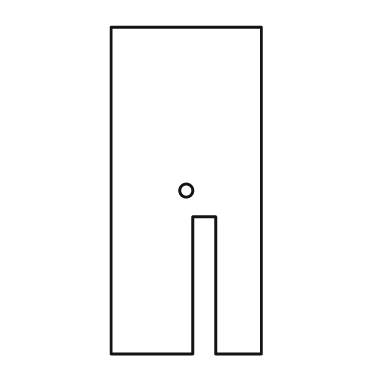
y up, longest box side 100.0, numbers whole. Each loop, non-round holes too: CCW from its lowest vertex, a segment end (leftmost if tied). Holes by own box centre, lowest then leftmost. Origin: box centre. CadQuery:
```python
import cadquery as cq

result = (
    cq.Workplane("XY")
    .moveTo(-23.0, -50.0)
    .lineTo(2.0, -50.0)
    .lineTo(2.0, -8.0)
    .lineTo(9.0, -8.0)
    .lineTo(9.0, -50.0)
    .lineTo(23.0, -50.0)
    .lineTo(23.0, 50.0)
    .lineTo(-23.0, 50.0)
    .close()
    .moveTo(0.0, 0.0)
    .circle(2.0)
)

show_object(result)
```